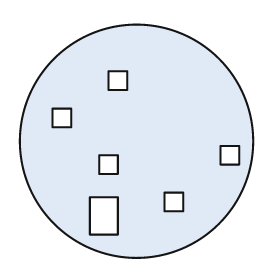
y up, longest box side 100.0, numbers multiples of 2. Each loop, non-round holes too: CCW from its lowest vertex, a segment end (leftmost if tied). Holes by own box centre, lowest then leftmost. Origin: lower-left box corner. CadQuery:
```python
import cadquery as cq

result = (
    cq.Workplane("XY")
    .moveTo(50.0, 50.0)
    .circle(50.0)
    .moveTo(30.0, 10.0)
    .lineTo(42.0, 10.0)
    .lineTo(42.0, 26.0)
    .lineTo(30.0, 26.0)
    .close()
    .moveTo(62.0, 20.0)
    .lineTo(70.0, 20.0)
    .lineTo(70.0, 28.0)
    .lineTo(62.0, 28.0)
    .close()
    .moveTo(34.0, 36.0)
    .lineTo(42.0, 36.0)
    .lineTo(42.0, 44.0)
    .lineTo(34.0, 44.0)
    .close()
    .moveTo(86.0, 40.0)
    .lineTo(94.0, 40.0)
    .lineTo(94.0, 48.0)
    .lineTo(86.0, 48.0)
    .close()
    .moveTo(14.0, 56.0)
    .lineTo(22.0, 56.0)
    .lineTo(22.0, 64.0)
    .lineTo(14.0, 64.0)
    .close()
    .moveTo(38.0, 72.0)
    .lineTo(46.0, 72.0)
    .lineTo(46.0, 80.0)
    .lineTo(38.0, 80.0)
    .close()
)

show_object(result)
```